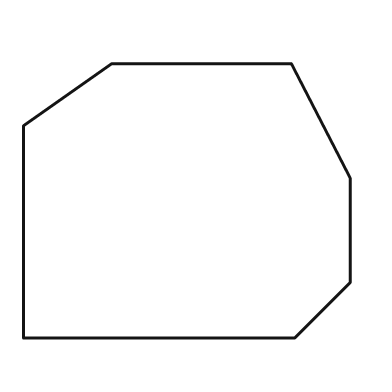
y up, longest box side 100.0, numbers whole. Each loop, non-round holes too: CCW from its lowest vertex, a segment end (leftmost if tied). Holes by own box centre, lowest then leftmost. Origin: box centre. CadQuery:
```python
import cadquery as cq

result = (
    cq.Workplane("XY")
    .moveTo(-50.0, -42.0)
    .lineTo(33.0, -42.0)
    .lineTo(50.0, -25.0)
    .lineTo(50.0, 7.0)
    .lineTo(32.0, 42.0)
    .lineTo(-23.0, 42.0)
    .lineTo(-50.0, 23.0)
    .close()
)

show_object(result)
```